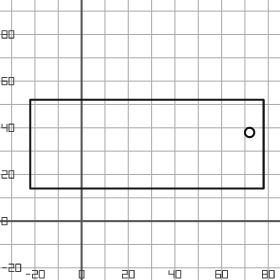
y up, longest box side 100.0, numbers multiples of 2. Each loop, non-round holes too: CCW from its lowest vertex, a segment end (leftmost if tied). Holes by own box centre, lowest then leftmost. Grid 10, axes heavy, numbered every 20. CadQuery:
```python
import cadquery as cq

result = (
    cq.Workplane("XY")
    .moveTo(-22.0, 14.0)
    .lineTo(78.0, 14.0)
    .lineTo(78.0, 52.0)
    .lineTo(-22.0, 52.0)
    .close()
    .moveTo(72.0, 38.0)
    .circle(2.0)
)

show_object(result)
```